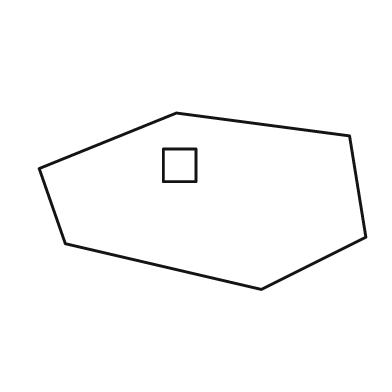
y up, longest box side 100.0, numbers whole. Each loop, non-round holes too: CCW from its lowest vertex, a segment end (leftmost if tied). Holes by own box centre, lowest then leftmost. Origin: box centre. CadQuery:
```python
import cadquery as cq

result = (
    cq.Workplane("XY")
    .moveTo(18.0, -27.0)
    .lineTo(50.0, -11.0)
    .lineTo(45.0, 20.0)
    .lineTo(-8.0, 27.0)
    .lineTo(-50.0, 10.0)
    .lineTo(-42.0, -13.0)
    .close()
    .moveTo(-12.0, 6.0)
    .lineTo(-2.0, 6.0)
    .lineTo(-2.0, 16.0)
    .lineTo(-12.0, 16.0)
    .close()
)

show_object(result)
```